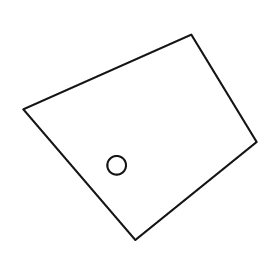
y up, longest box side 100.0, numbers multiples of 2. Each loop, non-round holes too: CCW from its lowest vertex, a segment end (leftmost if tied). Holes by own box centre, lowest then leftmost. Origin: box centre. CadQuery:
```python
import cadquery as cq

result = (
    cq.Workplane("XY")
    .moveTo(-2.0, -44.0)
    .lineTo(50.0, -2.0)
    .lineTo(22.0, 44.0)
    .lineTo(-50.0, 12.0)
    .close()
    .moveTo(-10.0, -12.0)
    .circle(4.0)
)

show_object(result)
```